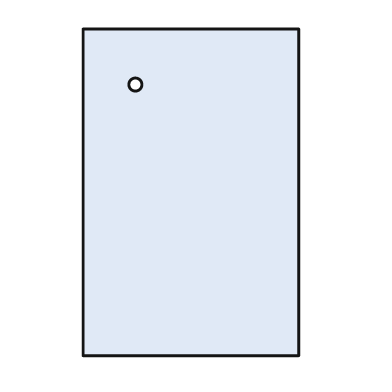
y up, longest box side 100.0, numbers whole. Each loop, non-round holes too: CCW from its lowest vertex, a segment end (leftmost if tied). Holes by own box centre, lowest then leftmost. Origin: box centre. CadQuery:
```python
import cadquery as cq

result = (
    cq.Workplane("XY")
    .moveTo(-33.0, -50.0)
    .lineTo(33.0, -50.0)
    .lineTo(33.0, 50.0)
    .lineTo(-33.0, 50.0)
    .close()
    .moveTo(-17.0, 33.0)
    .circle(2.0)
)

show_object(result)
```